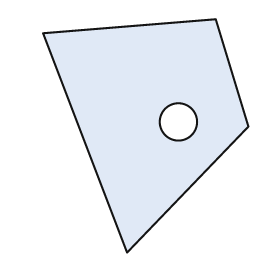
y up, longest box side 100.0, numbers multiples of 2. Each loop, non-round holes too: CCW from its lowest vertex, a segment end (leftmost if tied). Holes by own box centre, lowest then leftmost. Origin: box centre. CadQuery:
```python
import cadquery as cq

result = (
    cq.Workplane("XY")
    .moveTo(-8.0, -50.0)
    .lineTo(44.0, 4.0)
    .lineTo(30.0, 50.0)
    .lineTo(-44.0, 44.0)
    .close()
    .moveTo(14.0, 6.0)
    .circle(8.0)
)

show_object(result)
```